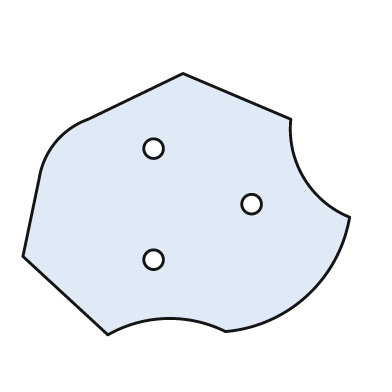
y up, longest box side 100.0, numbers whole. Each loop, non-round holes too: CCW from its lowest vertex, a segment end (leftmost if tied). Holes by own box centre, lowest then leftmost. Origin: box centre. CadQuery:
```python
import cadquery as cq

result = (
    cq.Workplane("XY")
    .moveTo(-24.0, -40.0)
    .threePointArc((-6.0, -35.0), (12.0, -39.0))
    .threePointArc((37.0, -28.0), (50.0, -4.0))
    .threePointArc((36.0, 8.0), (32.0, 26.0))
    .lineTo(-1.0, 40.0)
    .lineTo(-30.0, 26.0)
    .threePointArc((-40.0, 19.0), (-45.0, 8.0))
    .lineTo(-50.0, -16.0)
    .close()
    .moveTo(-10.0, -17.0)
    .circle(3.0)
    .moveTo(20.0, 0.0)
    .circle(3.0)
    .moveTo(-10.0, 17.0)
    .circle(3.0)
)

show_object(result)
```